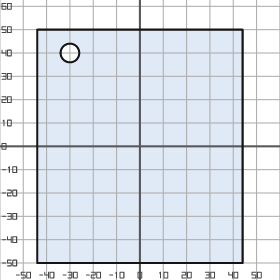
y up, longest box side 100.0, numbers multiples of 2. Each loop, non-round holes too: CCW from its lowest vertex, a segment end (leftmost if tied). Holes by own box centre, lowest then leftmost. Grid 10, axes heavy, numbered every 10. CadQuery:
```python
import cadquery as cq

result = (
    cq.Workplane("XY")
    .moveTo(-44.0, -50.0)
    .lineTo(44.0, -50.0)
    .lineTo(44.0, 50.0)
    .lineTo(-44.0, 50.0)
    .close()
    .moveTo(-30.0, 40.0)
    .circle(4.0)
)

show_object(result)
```